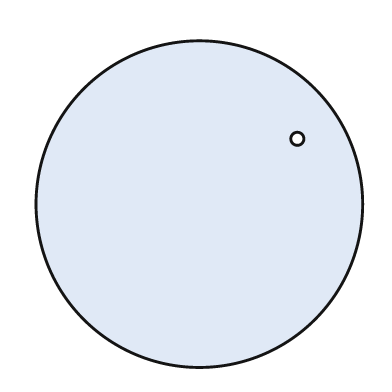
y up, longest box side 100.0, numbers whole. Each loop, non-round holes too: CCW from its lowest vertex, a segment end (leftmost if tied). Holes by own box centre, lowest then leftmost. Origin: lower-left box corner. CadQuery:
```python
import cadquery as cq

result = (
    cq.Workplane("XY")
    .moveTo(50.0, 50.0)
    .circle(50.0)
    .moveTo(80.0, 70.0)
    .circle(2.0)
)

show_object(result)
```